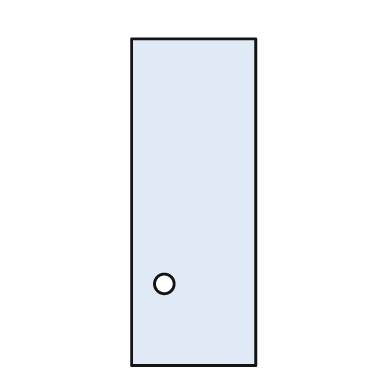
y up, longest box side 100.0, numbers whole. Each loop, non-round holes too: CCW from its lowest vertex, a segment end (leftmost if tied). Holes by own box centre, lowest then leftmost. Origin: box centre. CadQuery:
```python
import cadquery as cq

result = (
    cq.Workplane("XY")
    .moveTo(-19.0, -50.0)
    .lineTo(19.0, -50.0)
    .lineTo(19.0, 50.0)
    .lineTo(-19.0, 50.0)
    .close()
    .moveTo(-9.0, -25.0)
    .circle(3.0)
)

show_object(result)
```